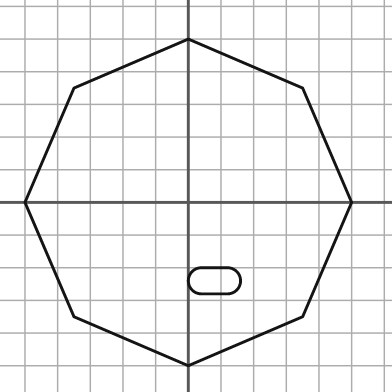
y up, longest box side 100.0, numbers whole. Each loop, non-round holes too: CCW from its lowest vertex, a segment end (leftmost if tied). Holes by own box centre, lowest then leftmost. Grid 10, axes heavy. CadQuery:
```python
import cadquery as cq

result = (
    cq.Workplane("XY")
    .moveTo(0.0, -50.0)
    .lineTo(35.0, -35.0)
    .lineTo(50.0, 0.0)
    .lineTo(35.0, 35.0)
    .lineTo(0.0, 50.0)
    .lineTo(-35.0, 35.0)
    .lineTo(-50.0, 0.0)
    .lineTo(-35.0, -35.0)
    .close()
    .moveTo(4.0, -28.0)
    .lineTo(12.0, -28.0)
    .threePointArc((16.0, -24.0), (12.0, -20.0))
    .lineTo(4.0, -20.0)
    .threePointArc((0.0, -24.0), (4.0, -28.0))
    .close()
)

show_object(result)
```